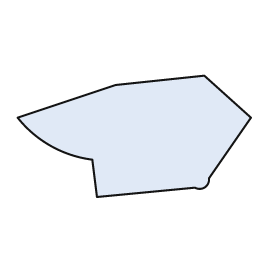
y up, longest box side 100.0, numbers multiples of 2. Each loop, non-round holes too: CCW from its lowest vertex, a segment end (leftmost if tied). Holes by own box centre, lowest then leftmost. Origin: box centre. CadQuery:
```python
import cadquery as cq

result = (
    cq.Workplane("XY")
    .moveTo(-16.0, -26.0)
    .lineTo(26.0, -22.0)
    .threePointArc((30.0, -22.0), (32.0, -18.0))
    .lineTo(50.0, 8.0)
    .lineTo(30.0, 26.0)
    .lineTo(-8.0, 22.0)
    .lineTo(-50.0, 8.0)
    .threePointArc((-36.0, -4.0), (-18.0, -10.0))
    .close()
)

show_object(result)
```